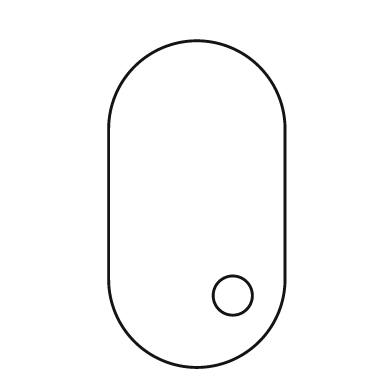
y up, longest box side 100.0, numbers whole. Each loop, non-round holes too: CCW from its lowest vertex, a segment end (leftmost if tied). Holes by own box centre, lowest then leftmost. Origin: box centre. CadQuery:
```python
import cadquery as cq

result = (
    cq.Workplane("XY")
    .moveTo(-27.0, -23.0)
    .threePointArc((0.0, -50.0), (27.0, -23.0))
    .lineTo(27.0, 23.0)
    .threePointArc((0.0, 50.0), (-27.0, 23.0))
    .close()
    .moveTo(11.0, -28.0)
    .circle(6.0)
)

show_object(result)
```